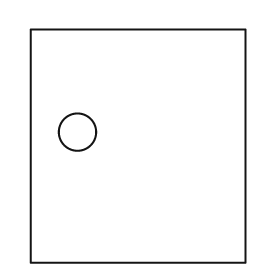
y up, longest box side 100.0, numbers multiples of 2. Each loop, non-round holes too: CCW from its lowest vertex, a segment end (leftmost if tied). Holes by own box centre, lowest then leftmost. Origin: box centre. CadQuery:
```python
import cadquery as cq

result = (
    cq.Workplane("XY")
    .moveTo(-46.0, -50.0)
    .lineTo(46.0, -50.0)
    .lineTo(46.0, 50.0)
    .lineTo(-46.0, 50.0)
    .close()
    .moveTo(-26.0, 6.0)
    .circle(8.0)
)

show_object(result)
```